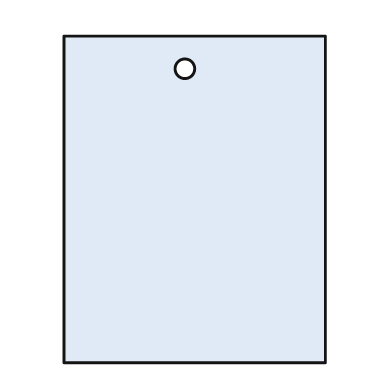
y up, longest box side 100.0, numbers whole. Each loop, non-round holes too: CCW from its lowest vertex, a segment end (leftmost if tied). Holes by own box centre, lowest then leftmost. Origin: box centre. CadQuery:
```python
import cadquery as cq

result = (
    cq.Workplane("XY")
    .moveTo(-40.0, -50.0)
    .lineTo(40.0, -50.0)
    .lineTo(40.0, 50.0)
    .lineTo(-40.0, 50.0)
    .close()
    .moveTo(-3.0, 40.0)
    .circle(3.0)
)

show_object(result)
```